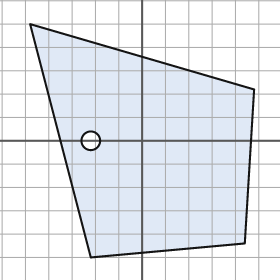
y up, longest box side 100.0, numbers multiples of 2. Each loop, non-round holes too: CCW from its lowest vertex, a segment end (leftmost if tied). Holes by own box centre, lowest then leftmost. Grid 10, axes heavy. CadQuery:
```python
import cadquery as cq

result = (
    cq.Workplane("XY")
    .moveTo(-22.0, -50.0)
    .lineTo(44.0, -44.0)
    .lineTo(48.0, 22.0)
    .lineTo(-48.0, 50.0)
    .close()
    .moveTo(-22.0, 0.0)
    .circle(4.0)
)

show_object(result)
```